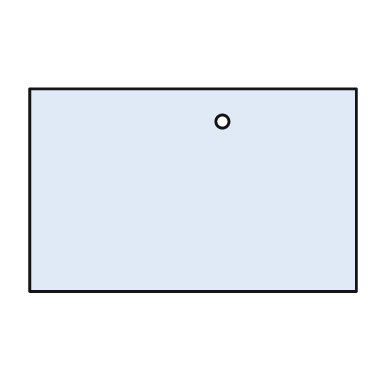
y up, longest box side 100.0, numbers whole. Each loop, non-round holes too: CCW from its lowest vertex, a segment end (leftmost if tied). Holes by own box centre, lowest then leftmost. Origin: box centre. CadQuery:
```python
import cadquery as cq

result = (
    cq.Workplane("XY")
    .moveTo(-50.0, -31.0)
    .lineTo(50.0, -31.0)
    .lineTo(50.0, 31.0)
    .lineTo(-50.0, 31.0)
    .close()
    .moveTo(9.0, 21.0)
    .circle(2.0)
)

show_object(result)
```